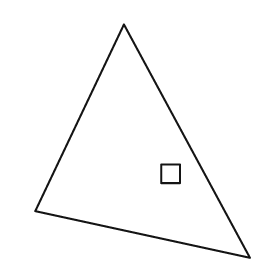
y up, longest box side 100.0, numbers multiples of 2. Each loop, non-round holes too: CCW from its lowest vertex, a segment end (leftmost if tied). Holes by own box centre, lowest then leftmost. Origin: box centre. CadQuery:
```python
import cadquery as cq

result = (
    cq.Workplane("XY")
    .moveTo(46.0, -50.0)
    .lineTo(-8.0, 50.0)
    .lineTo(-46.0, -30.0)
    .close()
    .moveTo(8.0, -18.0)
    .lineTo(16.0, -18.0)
    .lineTo(16.0, -10.0)
    .lineTo(8.0, -10.0)
    .close()
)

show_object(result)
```